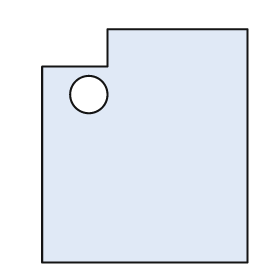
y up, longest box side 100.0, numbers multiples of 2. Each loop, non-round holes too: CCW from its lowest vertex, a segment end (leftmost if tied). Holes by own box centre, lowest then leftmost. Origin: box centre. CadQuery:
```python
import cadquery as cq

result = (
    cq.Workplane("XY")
    .moveTo(-44.0, -50.0)
    .lineTo(44.0, -50.0)
    .lineTo(44.0, 50.0)
    .lineTo(-16.0, 50.0)
    .lineTo(-16.0, 34.0)
    .lineTo(-44.0, 34.0)
    .close()
    .moveTo(-24.0, 22.0)
    .circle(8.0)
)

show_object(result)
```